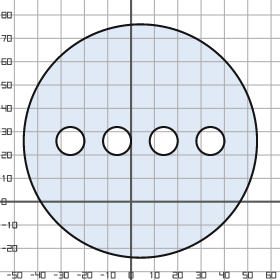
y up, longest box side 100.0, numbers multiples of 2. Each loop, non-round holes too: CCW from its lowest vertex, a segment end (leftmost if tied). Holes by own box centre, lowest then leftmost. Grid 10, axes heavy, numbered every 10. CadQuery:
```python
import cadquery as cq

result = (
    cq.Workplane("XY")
    .moveTo(4.0, 26.0)
    .circle(50.0)
    .moveTo(-26.0, 26.0)
    .circle(6.0)
    .moveTo(-6.0, 26.0)
    .circle(6.0)
    .moveTo(14.0, 26.0)
    .circle(6.0)
    .moveTo(34.0, 26.0)
    .circle(6.0)
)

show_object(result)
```